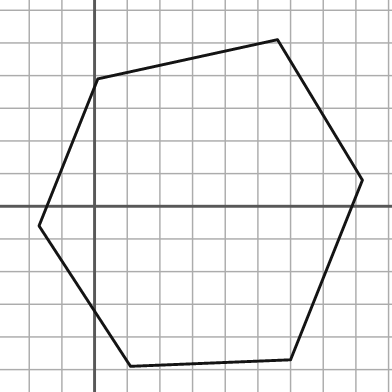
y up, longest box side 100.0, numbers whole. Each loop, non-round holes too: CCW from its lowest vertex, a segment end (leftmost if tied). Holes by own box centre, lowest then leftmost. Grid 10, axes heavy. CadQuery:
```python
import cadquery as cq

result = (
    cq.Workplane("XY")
    .moveTo(11.0, -49.0)
    .lineTo(60.0, -47.0)
    .lineTo(82.0, 8.0)
    .lineTo(56.0, 51.0)
    .lineTo(1.0, 39.0)
    .lineTo(-17.0, -6.0)
    .close()
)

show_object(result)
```